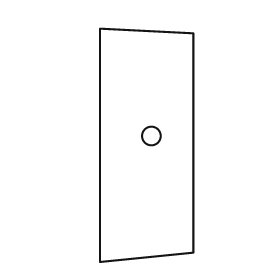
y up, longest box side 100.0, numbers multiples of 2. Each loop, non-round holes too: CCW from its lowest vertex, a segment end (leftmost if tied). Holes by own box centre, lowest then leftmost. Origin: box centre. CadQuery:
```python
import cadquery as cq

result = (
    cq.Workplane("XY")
    .moveTo(-20.0, -50.0)
    .lineTo(20.0, -46.0)
    .lineTo(20.0, 48.0)
    .lineTo(-20.0, 50.0)
    .close()
    .moveTo(2.0, 4.0)
    .circle(4.0)
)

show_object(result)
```